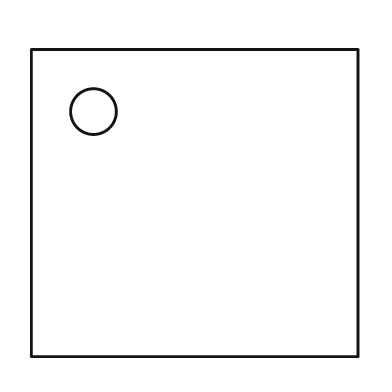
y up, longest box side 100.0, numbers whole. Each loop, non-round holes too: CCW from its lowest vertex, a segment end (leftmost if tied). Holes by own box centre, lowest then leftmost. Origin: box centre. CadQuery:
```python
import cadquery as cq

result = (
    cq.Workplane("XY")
    .moveTo(-50.0, -47.0)
    .lineTo(50.0, -47.0)
    .lineTo(50.0, 47.0)
    .lineTo(-50.0, 47.0)
    .close()
    .moveTo(-31.0, 28.0)
    .circle(7.0)
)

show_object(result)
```